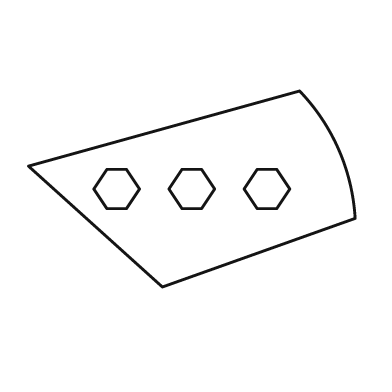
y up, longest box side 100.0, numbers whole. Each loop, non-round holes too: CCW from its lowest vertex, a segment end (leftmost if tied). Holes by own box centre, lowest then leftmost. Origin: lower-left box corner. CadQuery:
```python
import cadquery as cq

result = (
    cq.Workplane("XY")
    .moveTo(41.0, 0.0)
    .lineTo(100.0, 21.0)
    .threePointArc((95.0, 42.0), (83.0, 60.0))
    .lineTo(0.0, 37.0)
    .close()
    .moveTo(24.0, 24.0)
    .lineTo(30.0, 24.0)
    .lineTo(34.0, 30.0)
    .lineTo(30.0, 36.0)
    .lineTo(24.0, 36.0)
    .lineTo(20.0, 30.0)
    .close()
    .moveTo(47.0, 24.0)
    .lineTo(53.0, 24.0)
    .lineTo(57.0, 30.0)
    .lineTo(53.0, 36.0)
    .lineTo(47.0, 36.0)
    .lineTo(43.0, 30.0)
    .close()
    .moveTo(70.0, 24.0)
    .lineTo(76.0, 24.0)
    .lineTo(80.0, 30.0)
    .lineTo(76.0, 36.0)
    .lineTo(70.0, 36.0)
    .lineTo(66.0, 30.0)
    .close()
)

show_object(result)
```